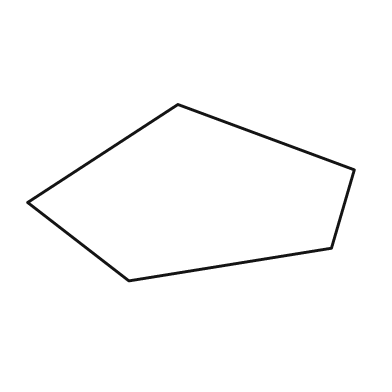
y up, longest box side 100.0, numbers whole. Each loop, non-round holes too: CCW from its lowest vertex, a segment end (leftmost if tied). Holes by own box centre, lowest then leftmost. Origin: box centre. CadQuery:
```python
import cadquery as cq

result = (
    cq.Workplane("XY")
    .moveTo(-19.0, -27.0)
    .lineTo(43.0, -17.0)
    .lineTo(50.0, 7.0)
    .lineTo(-4.0, 27.0)
    .lineTo(-50.0, -3.0)
    .close()
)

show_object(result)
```